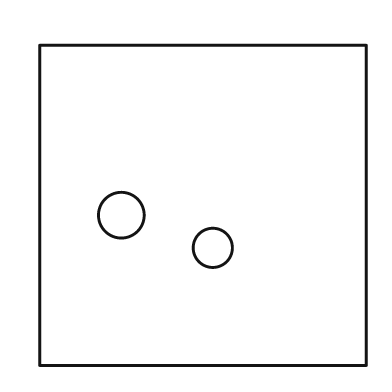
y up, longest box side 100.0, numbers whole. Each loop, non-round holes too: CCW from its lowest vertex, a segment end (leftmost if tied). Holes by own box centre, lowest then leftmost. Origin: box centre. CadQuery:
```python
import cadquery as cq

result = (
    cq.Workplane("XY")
    .moveTo(-50.0, -49.0)
    .lineTo(50.0, -49.0)
    .lineTo(50.0, 49.0)
    .lineTo(-50.0, 49.0)
    .close()
    .moveTo(3.0, -13.0)
    .circle(6.0)
    .moveTo(-25.0, -3.0)
    .circle(7.0)
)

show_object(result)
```